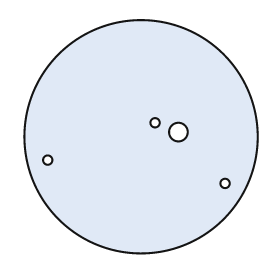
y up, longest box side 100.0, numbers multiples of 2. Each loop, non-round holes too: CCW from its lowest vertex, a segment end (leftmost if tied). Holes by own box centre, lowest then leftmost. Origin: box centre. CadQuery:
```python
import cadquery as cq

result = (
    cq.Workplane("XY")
    .moveTo(0.0, 0.0)
    .circle(50.0)
    .moveTo(36.0, -20.0)
    .circle(2.0)
    .moveTo(-40.0, -10.0)
    .circle(2.0)
    .moveTo(16.0, 2.0)
    .circle(4.0)
    .moveTo(6.0, 6.0)
    .circle(2.0)
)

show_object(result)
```